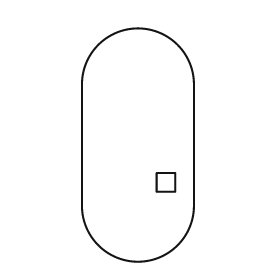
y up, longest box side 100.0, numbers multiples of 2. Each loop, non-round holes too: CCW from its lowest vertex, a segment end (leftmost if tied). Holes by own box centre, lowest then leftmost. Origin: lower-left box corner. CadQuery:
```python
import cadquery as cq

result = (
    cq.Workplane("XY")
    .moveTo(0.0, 24.0)
    .threePointArc((24.0, 0.0), (48.0, 24.0))
    .lineTo(48.0, 76.0)
    .threePointArc((24.0, 100.0), (0.0, 76.0))
    .close()
    .moveTo(32.0, 30.0)
    .lineTo(40.0, 30.0)
    .lineTo(40.0, 38.0)
    .lineTo(32.0, 38.0)
    .close()
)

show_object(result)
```